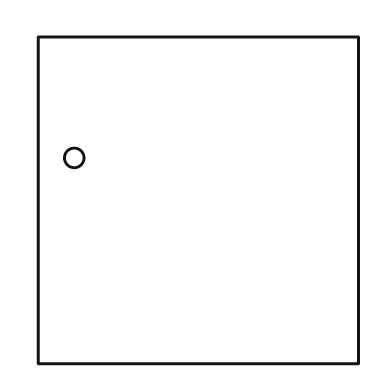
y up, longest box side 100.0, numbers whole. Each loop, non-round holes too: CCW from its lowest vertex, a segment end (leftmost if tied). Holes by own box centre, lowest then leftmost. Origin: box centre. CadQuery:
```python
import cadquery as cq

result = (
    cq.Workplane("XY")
    .moveTo(-49.0, -50.0)
    .lineTo(49.0, -50.0)
    .lineTo(49.0, 50.0)
    .lineTo(-49.0, 50.0)
    .close()
    .moveTo(-38.0, 13.0)
    .circle(3.0)
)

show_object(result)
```